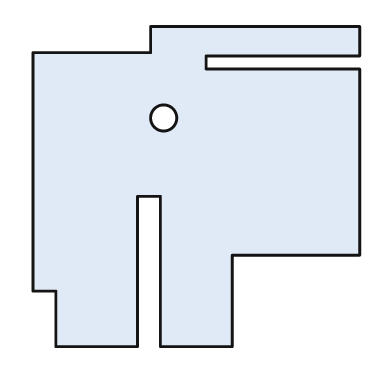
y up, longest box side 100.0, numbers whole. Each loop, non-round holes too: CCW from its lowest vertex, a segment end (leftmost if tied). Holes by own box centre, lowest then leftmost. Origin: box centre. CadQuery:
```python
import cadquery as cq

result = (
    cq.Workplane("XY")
    .moveTo(-43.0, -49.0)
    .lineTo(-18.0, -49.0)
    .lineTo(-18.0, -3.0)
    .lineTo(-11.0, -3.0)
    .lineTo(-11.0, -49.0)
    .lineTo(11.0, -49.0)
    .lineTo(11.0, -21.0)
    .lineTo(50.0, -21.0)
    .lineTo(50.0, 36.0)
    .lineTo(3.0, 36.0)
    .lineTo(3.0, 40.0)
    .lineTo(50.0, 40.0)
    .lineTo(50.0, 49.0)
    .lineTo(-14.0, 49.0)
    .lineTo(-14.0, 41.0)
    .lineTo(-50.0, 41.0)
    .lineTo(-50.0, -32.0)
    .lineTo(-43.0, -32.0)
    .close()
    .moveTo(-10.0, 21.0)
    .circle(4.0)
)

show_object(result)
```